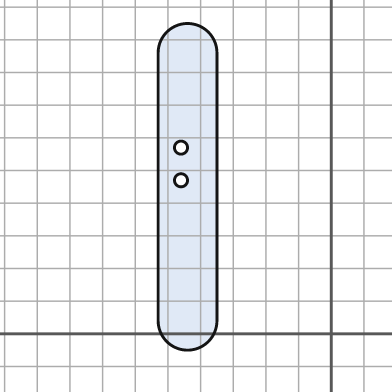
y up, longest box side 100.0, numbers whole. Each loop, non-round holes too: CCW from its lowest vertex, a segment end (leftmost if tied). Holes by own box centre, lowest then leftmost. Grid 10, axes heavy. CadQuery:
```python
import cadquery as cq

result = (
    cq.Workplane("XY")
    .moveTo(-53.0, 4.0)
    .threePointArc((-44.0, -5.0), (-35.0, 4.0))
    .lineTo(-35.0, 86.0)
    .threePointArc((-44.0, 95.0), (-53.0, 86.0))
    .close()
    .moveTo(-46.0, 47.0)
    .circle(2.0)
    .moveTo(-46.0, 57.0)
    .circle(2.0)
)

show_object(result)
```